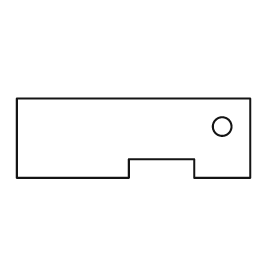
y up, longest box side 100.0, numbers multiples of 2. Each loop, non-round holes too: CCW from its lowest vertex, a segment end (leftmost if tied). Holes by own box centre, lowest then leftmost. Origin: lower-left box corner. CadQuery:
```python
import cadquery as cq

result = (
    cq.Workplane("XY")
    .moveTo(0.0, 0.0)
    .lineTo(48.0, 0.0)
    .lineTo(48.0, 8.0)
    .lineTo(76.0, 8.0)
    .lineTo(76.0, 0.0)
    .lineTo(100.0, 0.0)
    .lineTo(100.0, 34.0)
    .lineTo(0.0, 34.0)
    .close()
    .moveTo(88.0, 22.0)
    .circle(4.0)
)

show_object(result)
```